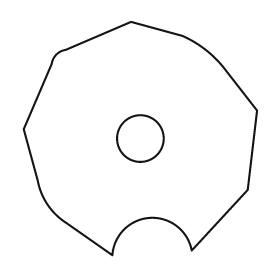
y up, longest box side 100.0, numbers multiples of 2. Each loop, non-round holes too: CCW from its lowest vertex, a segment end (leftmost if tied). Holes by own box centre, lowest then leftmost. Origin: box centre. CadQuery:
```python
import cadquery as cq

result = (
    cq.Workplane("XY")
    .moveTo(-12.0, -50.0)
    .threePointArc((4.0, -34.0), (22.0, -48.0))
    .lineTo(46.0, -22.0)
    .lineTo(50.0, 12.0)
    .lineTo(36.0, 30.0)
    .threePointArc((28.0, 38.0), (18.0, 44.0))
    .lineTo(-4.0, 50.0)
    .lineTo(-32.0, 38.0)
    .threePointArc((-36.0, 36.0), (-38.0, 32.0))
    .lineTo(-50.0, 4.0)
    .lineTo(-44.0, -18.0)
    .threePointArc((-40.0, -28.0), (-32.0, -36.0))
    .close()
    .moveTo(0.0, 0.0)
    .circle(10.0)
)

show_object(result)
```